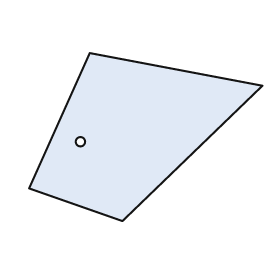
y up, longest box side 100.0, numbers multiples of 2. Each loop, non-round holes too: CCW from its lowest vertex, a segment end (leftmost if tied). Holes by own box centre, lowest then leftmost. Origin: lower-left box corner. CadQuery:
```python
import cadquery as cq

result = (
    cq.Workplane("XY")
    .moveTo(40.0, 0.0)
    .lineTo(100.0, 58.0)
    .lineTo(26.0, 72.0)
    .lineTo(0.0, 14.0)
    .close()
    .moveTo(22.0, 34.0)
    .circle(2.0)
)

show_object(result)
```